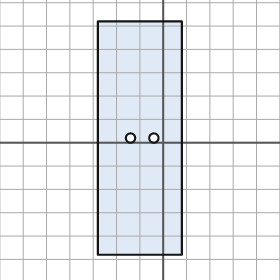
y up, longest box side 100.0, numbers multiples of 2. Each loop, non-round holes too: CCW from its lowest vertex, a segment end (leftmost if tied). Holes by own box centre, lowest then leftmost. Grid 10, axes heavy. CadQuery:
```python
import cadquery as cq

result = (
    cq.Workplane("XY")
    .moveTo(-28.0, -48.0)
    .lineTo(8.0, -48.0)
    .lineTo(8.0, 52.0)
    .lineTo(-28.0, 52.0)
    .close()
    .moveTo(-14.0, 2.0)
    .circle(2.0)
    .moveTo(-4.0, 2.0)
    .circle(2.0)
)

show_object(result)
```